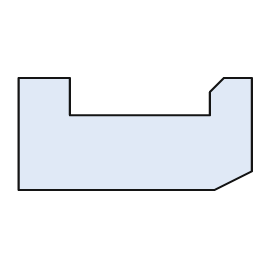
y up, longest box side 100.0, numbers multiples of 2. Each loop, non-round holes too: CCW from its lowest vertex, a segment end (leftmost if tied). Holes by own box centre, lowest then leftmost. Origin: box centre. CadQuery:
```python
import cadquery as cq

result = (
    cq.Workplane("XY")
    .moveTo(-50.0, -24.0)
    .lineTo(34.0, -24.0)
    .lineTo(50.0, -16.0)
    .lineTo(50.0, 24.0)
    .lineTo(38.0, 24.0)
    .lineTo(32.0, 18.0)
    .lineTo(32.0, 8.0)
    .lineTo(-28.0, 8.0)
    .lineTo(-28.0, 24.0)
    .lineTo(-50.0, 24.0)
    .close()
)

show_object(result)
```